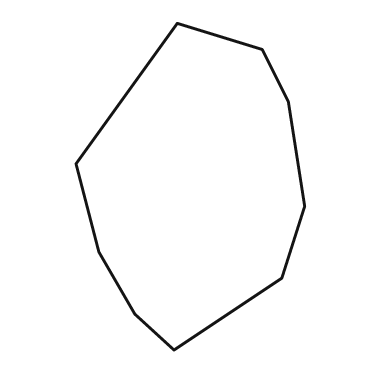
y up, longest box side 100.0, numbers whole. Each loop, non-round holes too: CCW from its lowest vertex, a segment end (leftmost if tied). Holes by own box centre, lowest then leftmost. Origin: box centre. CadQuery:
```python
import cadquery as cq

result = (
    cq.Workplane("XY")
    .moveTo(-5.0, -50.0)
    .lineTo(28.0, -28.0)
    .lineTo(35.0, -6.0)
    .lineTo(30.0, 26.0)
    .lineTo(22.0, 42.0)
    .lineTo(-4.0, 50.0)
    .lineTo(-35.0, 7.0)
    .lineTo(-28.0, -20.0)
    .lineTo(-17.0, -39.0)
    .close()
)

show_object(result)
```